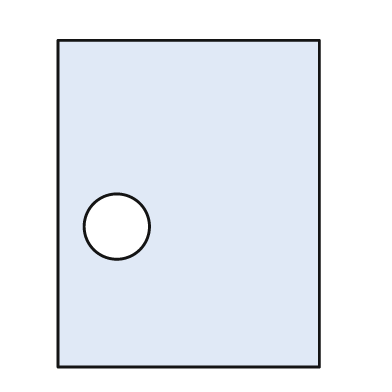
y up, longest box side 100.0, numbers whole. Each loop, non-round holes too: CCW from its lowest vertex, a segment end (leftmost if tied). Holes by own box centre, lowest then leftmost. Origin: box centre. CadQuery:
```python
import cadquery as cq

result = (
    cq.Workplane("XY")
    .moveTo(-40.0, -50.0)
    .lineTo(40.0, -50.0)
    .lineTo(40.0, 50.0)
    .lineTo(-40.0, 50.0)
    .close()
    .moveTo(-22.0, -7.0)
    .circle(10.0)
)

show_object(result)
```